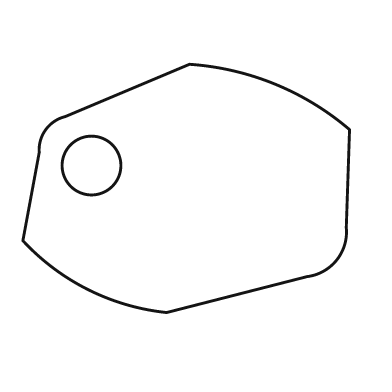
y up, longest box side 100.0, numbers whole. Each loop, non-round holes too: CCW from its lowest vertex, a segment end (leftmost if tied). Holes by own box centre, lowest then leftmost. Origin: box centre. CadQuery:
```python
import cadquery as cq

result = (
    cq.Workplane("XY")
    .moveTo(-6.0, -38.0)
    .lineTo(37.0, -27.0)
    .threePointArc((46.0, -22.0), (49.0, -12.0))
    .lineTo(50.0, 18.0)
    .threePointArc((27.0, 32.0), (1.0, 38.0))
    .lineTo(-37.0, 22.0)
    .threePointArc((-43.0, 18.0), (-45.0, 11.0))
    .lineTo(-50.0, -16.0)
    .threePointArc((-30.0, -31.0), (-6.0, -38.0))
    .close()
    .moveTo(-29.0, 7.0)
    .circle(9.0)
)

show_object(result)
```